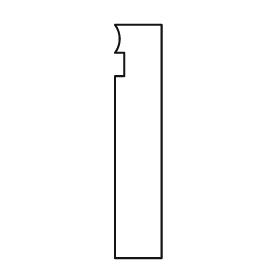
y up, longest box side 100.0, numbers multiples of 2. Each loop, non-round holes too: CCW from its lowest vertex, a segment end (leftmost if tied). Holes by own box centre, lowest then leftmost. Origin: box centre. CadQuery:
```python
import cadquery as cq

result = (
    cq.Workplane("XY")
    .moveTo(-10.0, -50.0)
    .lineTo(10.0, -50.0)
    .lineTo(10.0, 50.0)
    .lineTo(-10.0, 50.0)
    .threePointArc((-8.0, 44.0), (-10.0, 38.0))
    .lineTo(-6.0, 38.0)
    .lineTo(-6.0, 28.0)
    .lineTo(-10.0, 28.0)
    .close()
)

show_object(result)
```